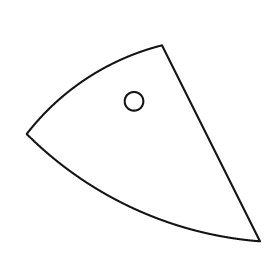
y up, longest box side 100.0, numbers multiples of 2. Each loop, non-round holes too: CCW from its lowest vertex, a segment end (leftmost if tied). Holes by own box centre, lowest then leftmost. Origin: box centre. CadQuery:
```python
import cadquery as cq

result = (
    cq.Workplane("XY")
    .moveTo(50.0, -42.0)
    .lineTo(8.0, 42.0)
    .threePointArc((-24.0, 28.0), (-50.0, 4.0))
    .threePointArc((-4.0, -28.0), (50.0, -42.0))
    .close()
    .moveTo(-4.0, 18.0)
    .circle(4.0)
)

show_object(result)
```